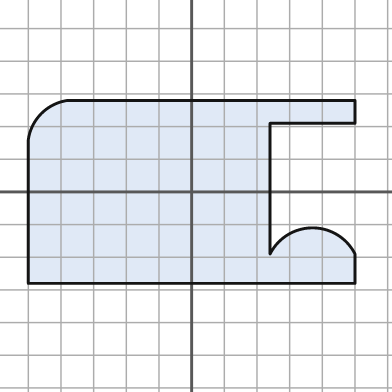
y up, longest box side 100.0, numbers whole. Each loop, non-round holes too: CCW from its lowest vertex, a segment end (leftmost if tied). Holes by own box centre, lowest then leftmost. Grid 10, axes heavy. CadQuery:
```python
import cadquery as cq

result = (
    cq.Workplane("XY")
    .moveTo(-50.0, -28.0)
    .lineTo(50.0, -28.0)
    .lineTo(50.0, -19.0)
    .threePointArc((37.0, -11.0), (24.0, -19.0))
    .lineTo(24.0, 21.0)
    .lineTo(50.0, 21.0)
    .lineTo(50.0, 28.0)
    .lineTo(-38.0, 28.0)
    .threePointArc((-46.0, 24.0), (-50.0, 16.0))
    .close()
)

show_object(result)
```